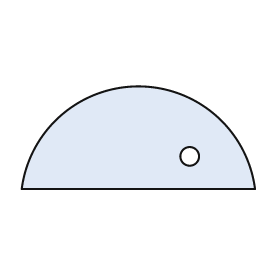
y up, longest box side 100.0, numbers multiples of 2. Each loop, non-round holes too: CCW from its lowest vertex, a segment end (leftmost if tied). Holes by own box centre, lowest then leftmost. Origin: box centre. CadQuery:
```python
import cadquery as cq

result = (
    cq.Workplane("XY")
    .moveTo(-50.0, -22.0)
    .lineTo(50.0, -22.0)
    .threePointArc((0.0, 22.0), (-50.0, -22.0))
    .close()
    .moveTo(22.0, -8.0)
    .circle(4.0)
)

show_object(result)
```